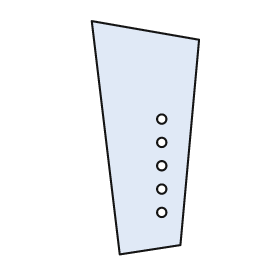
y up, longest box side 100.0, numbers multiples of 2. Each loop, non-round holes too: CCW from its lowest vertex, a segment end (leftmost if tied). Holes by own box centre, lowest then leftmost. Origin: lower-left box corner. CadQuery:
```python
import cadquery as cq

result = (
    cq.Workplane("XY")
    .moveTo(12.0, 0.0)
    .lineTo(38.0, 4.0)
    .lineTo(46.0, 92.0)
    .lineTo(0.0, 100.0)
    .close()
    .moveTo(30.0, 18.0)
    .circle(2.0)
    .moveTo(30.0, 28.0)
    .circle(2.0)
    .moveTo(30.0, 38.0)
    .circle(2.0)
    .moveTo(30.0, 48.0)
    .circle(2.0)
    .moveTo(30.0, 58.0)
    .circle(2.0)
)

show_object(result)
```